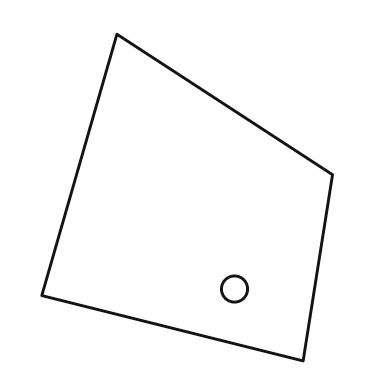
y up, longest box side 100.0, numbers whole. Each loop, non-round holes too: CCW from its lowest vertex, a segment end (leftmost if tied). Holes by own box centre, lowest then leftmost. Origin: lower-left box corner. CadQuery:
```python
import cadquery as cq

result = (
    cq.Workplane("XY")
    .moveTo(80.0, 0.0)
    .lineTo(89.0, 57.0)
    .lineTo(23.0, 100.0)
    .lineTo(0.0, 20.0)
    .close()
    .moveTo(59.0, 22.0)
    .circle(4.0)
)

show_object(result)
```